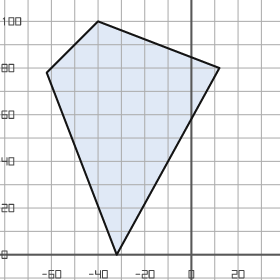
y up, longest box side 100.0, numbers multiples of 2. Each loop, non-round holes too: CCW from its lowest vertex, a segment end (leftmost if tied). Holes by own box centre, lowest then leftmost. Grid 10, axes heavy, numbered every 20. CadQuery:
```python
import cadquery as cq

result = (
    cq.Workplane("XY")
    .moveTo(-32.0, 0.0)
    .lineTo(12.0, 80.0)
    .lineTo(-40.0, 100.0)
    .lineTo(-62.0, 78.0)
    .close()
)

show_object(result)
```